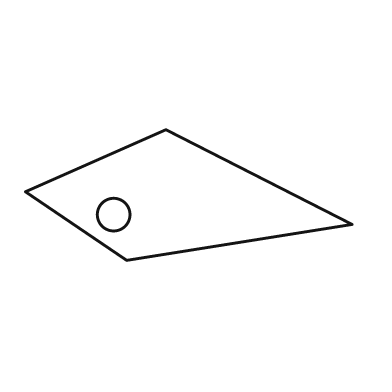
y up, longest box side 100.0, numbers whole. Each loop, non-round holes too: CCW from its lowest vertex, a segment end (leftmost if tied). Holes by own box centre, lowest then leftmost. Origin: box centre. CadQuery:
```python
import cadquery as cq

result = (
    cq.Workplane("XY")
    .moveTo(-19.0, -20.0)
    .lineTo(50.0, -9.0)
    .lineTo(-7.0, 20.0)
    .lineTo(-50.0, 1.0)
    .close()
    .moveTo(-23.0, -6.0)
    .circle(5.0)
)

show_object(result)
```